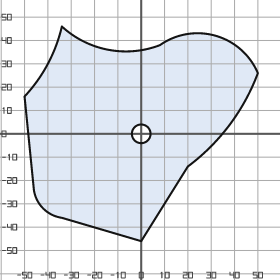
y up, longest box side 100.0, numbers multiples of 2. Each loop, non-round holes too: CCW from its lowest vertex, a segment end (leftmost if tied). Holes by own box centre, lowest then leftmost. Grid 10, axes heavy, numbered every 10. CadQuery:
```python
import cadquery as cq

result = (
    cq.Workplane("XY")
    .moveTo(0.0, -46.0)
    .lineTo(20.0, -14.0)
    .threePointArc((38.0, 4.0), (50.0, 26.0))
    .threePointArc((32.0, 42.0), (8.0, 38.0))
    .threePointArc((-14.0, 36.0), (-34.0, 46.0))
    .threePointArc((-40.0, 30.0), (-50.0, 16.0))
    .lineTo(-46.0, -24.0)
    .threePointArc((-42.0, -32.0), (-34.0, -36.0))
    .close()
    .moveTo(0.0, 0.0)
    .circle(4.0)
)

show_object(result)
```